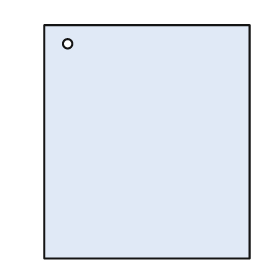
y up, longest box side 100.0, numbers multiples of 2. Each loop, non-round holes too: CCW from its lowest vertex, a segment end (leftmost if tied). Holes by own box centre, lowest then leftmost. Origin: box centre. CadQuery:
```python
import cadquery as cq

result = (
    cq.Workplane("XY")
    .moveTo(-44.0, -50.0)
    .lineTo(44.0, -50.0)
    .lineTo(44.0, 50.0)
    .lineTo(-44.0, 50.0)
    .close()
    .moveTo(-34.0, 42.0)
    .circle(2.0)
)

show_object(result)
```